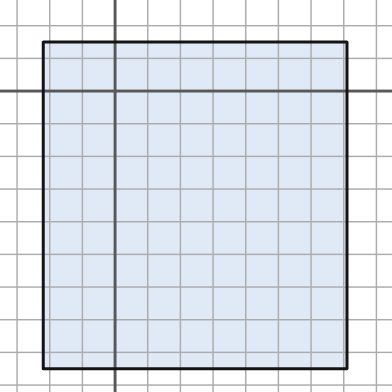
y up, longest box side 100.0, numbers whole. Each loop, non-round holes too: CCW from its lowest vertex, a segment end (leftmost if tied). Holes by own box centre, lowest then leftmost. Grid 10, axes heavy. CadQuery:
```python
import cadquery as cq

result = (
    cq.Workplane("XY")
    .moveTo(-22.0, -85.0)
    .lineTo(71.0, -85.0)
    .lineTo(71.0, 15.0)
    .lineTo(-22.0, 15.0)
    .close()
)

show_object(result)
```